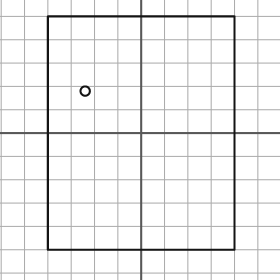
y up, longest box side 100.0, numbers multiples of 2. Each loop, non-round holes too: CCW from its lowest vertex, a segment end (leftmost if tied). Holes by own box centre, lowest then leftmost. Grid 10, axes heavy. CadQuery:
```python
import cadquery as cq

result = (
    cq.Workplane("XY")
    .moveTo(-40.0, -50.0)
    .lineTo(40.0, -50.0)
    .lineTo(40.0, 50.0)
    .lineTo(-40.0, 50.0)
    .close()
    .moveTo(-24.0, 18.0)
    .circle(2.0)
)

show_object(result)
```